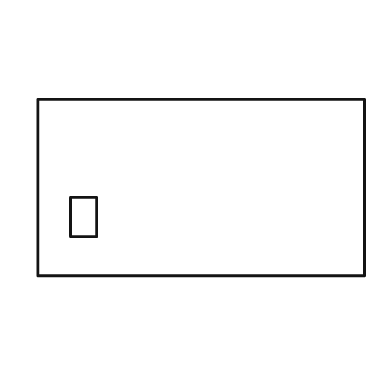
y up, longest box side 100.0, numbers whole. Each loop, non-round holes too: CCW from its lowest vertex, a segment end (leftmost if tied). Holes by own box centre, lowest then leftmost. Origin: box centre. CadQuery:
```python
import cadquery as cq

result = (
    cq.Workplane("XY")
    .moveTo(-50.0, -27.0)
    .lineTo(50.0, -27.0)
    .lineTo(50.0, 27.0)
    .lineTo(-50.0, 27.0)
    .close()
    .moveTo(-40.0, -15.0)
    .lineTo(-32.0, -15.0)
    .lineTo(-32.0, -3.0)
    .lineTo(-40.0, -3.0)
    .close()
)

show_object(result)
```